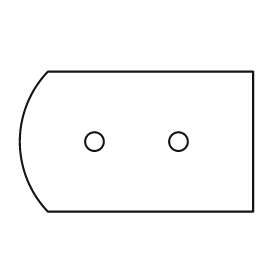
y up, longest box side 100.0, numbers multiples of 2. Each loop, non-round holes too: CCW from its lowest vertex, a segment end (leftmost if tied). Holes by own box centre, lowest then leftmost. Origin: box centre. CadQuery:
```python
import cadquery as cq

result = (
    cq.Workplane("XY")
    .moveTo(-38.0, -30.0)
    .lineTo(50.0, -30.0)
    .lineTo(50.0, 30.0)
    .lineTo(-38.0, 30.0)
    .threePointArc((-50.0, 0.0), (-38.0, -30.0))
    .close()
    .moveTo(-18.0, 0.0)
    .circle(4.0)
    .moveTo(18.0, 0.0)
    .circle(4.0)
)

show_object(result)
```